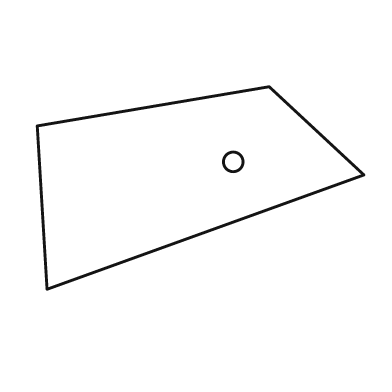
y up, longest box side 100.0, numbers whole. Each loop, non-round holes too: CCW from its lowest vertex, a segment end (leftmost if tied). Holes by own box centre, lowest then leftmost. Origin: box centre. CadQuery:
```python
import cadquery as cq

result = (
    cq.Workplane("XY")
    .moveTo(-47.0, -31.0)
    .lineTo(50.0, 4.0)
    .lineTo(21.0, 31.0)
    .lineTo(-50.0, 19.0)
    .close()
    .moveTo(10.0, 8.0)
    .circle(3.0)
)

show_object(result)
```